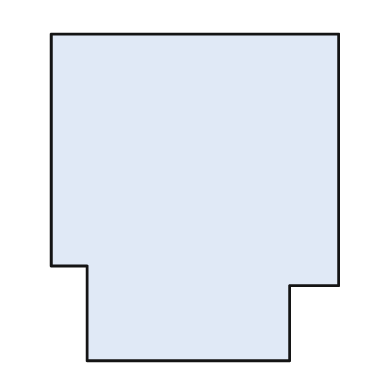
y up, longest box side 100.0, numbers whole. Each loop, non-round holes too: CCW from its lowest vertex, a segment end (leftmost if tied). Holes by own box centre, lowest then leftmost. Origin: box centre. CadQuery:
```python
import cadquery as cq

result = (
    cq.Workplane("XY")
    .moveTo(-33.0, -50.0)
    .lineTo(29.0, -50.0)
    .lineTo(29.0, -27.0)
    .lineTo(44.0, -27.0)
    .lineTo(44.0, 50.0)
    .lineTo(-44.0, 50.0)
    .lineTo(-44.0, -21.0)
    .lineTo(-33.0, -21.0)
    .close()
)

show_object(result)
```